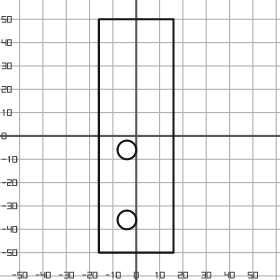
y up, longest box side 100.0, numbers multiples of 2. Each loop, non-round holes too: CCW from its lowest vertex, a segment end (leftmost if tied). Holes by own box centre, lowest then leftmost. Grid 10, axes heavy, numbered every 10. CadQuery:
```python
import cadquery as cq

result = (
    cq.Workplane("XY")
    .moveTo(-16.0, -50.0)
    .lineTo(16.0, -50.0)
    .lineTo(16.0, 50.0)
    .lineTo(-16.0, 50.0)
    .close()
    .moveTo(-4.0, -36.0)
    .circle(4.0)
    .moveTo(-4.0, -6.0)
    .circle(4.0)
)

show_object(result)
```